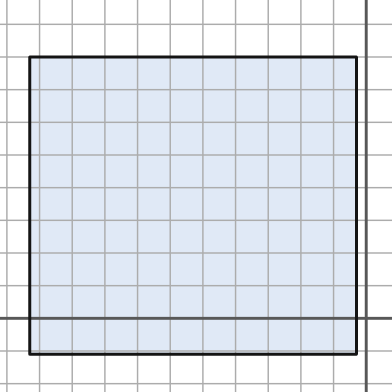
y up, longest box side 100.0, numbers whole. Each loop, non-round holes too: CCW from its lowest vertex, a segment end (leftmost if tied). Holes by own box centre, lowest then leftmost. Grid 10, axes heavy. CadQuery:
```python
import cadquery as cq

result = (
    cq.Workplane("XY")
    .moveTo(-103.0, -11.0)
    .lineTo(-3.0, -11.0)
    .lineTo(-3.0, 80.0)
    .lineTo(-103.0, 80.0)
    .close()
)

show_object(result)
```